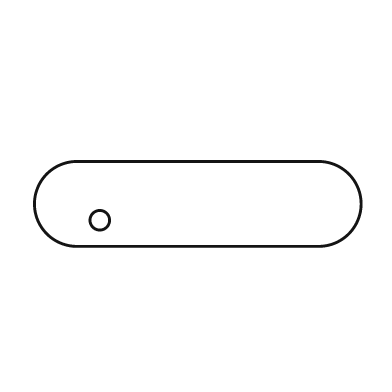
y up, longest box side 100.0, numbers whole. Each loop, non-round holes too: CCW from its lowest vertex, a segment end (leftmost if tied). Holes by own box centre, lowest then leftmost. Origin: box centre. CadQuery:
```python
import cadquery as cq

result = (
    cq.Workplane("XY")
    .moveTo(-37.0, -13.0)
    .lineTo(37.0, -13.0)
    .threePointArc((50.0, 0.0), (37.0, 13.0))
    .lineTo(-37.0, 13.0)
    .threePointArc((-50.0, 0.0), (-37.0, -13.0))
    .close()
    .moveTo(-30.0, -5.0)
    .circle(3.0)
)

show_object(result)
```